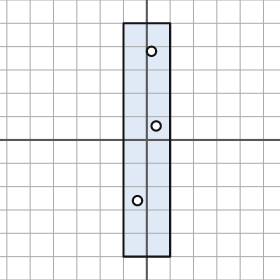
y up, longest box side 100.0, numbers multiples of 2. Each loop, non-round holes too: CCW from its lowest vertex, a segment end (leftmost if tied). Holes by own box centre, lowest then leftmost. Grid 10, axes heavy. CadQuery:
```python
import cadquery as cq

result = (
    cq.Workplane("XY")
    .moveTo(-10.0, -50.0)
    .lineTo(10.0, -50.0)
    .lineTo(10.0, 50.0)
    .lineTo(-10.0, 50.0)
    .close()
    .moveTo(-4.0, -26.0)
    .circle(2.0)
    .moveTo(4.0, 6.0)
    .circle(2.0)
    .moveTo(2.0, 38.0)
    .circle(2.0)
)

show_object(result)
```